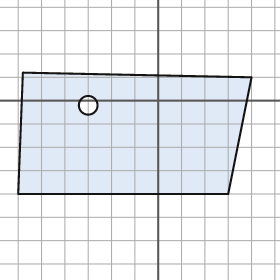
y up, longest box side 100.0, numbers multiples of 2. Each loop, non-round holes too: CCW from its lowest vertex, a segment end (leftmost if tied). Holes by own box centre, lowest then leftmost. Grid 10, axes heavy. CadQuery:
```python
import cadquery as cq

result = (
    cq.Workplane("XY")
    .moveTo(-60.0, -40.0)
    .lineTo(30.0, -40.0)
    .lineTo(40.0, 10.0)
    .lineTo(-58.0, 12.0)
    .close()
    .moveTo(-30.0, -2.0)
    .circle(4.0)
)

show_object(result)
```